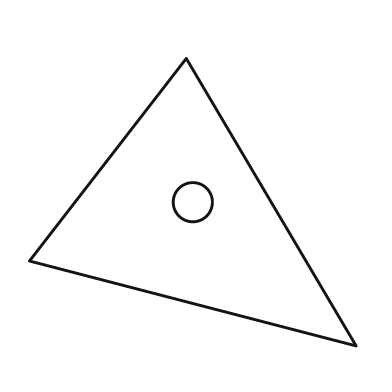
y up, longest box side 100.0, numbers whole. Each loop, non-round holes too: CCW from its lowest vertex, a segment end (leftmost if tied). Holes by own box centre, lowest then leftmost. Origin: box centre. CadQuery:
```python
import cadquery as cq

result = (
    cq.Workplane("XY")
    .moveTo(50.0, -44.0)
    .lineTo(-2.0, 44.0)
    .lineTo(-50.0, -18.0)
    .close()
    .moveTo(0.0, 0.0)
    .circle(6.0)
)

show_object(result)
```